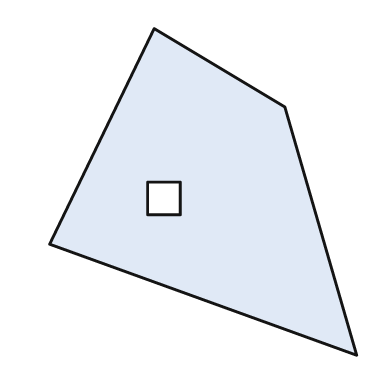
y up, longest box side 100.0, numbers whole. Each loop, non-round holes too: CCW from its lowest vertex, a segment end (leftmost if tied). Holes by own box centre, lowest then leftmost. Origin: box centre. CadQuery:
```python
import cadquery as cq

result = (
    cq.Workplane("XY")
    .moveTo(47.0, -50.0)
    .lineTo(25.0, 26.0)
    .lineTo(-15.0, 50.0)
    .lineTo(-47.0, -16.0)
    .close()
    .moveTo(-17.0, -7.0)
    .lineTo(-7.0, -7.0)
    .lineTo(-7.0, 3.0)
    .lineTo(-17.0, 3.0)
    .close()
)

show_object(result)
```